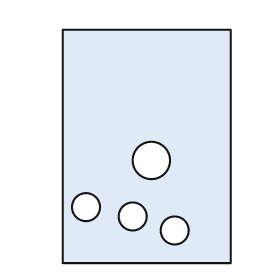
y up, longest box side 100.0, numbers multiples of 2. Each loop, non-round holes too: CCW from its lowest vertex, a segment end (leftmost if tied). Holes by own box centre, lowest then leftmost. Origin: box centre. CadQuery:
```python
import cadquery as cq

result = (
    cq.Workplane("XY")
    .moveTo(-36.0, -50.0)
    .lineTo(36.0, -50.0)
    .lineTo(36.0, 50.0)
    .lineTo(-36.0, 50.0)
    .close()
    .moveTo(12.0, -36.0)
    .circle(6.0)
    .moveTo(-6.0, -30.0)
    .circle(6.0)
    .moveTo(-26.0, -26.0)
    .circle(6.0)
    .moveTo(2.0, -6.0)
    .circle(8.0)
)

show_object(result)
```